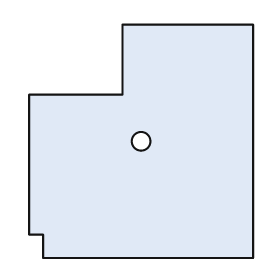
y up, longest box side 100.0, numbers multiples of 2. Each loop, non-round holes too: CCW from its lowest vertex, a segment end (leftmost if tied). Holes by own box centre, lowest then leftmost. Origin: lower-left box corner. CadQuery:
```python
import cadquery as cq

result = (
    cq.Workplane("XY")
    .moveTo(6.0, 0.0)
    .lineTo(96.0, 0.0)
    .lineTo(96.0, 100.0)
    .lineTo(40.0, 100.0)
    .lineTo(40.0, 70.0)
    .lineTo(0.0, 70.0)
    .lineTo(0.0, 10.0)
    .lineTo(6.0, 10.0)
    .close()
    .moveTo(48.0, 50.0)
    .circle(4.0)
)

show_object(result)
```